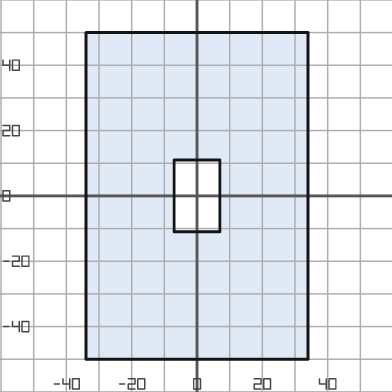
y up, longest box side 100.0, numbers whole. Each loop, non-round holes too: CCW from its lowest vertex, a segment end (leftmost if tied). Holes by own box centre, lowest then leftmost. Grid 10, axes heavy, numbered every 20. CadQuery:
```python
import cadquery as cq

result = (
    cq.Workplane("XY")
    .moveTo(-34.0, -50.0)
    .lineTo(34.0, -50.0)
    .lineTo(34.0, 50.0)
    .lineTo(-34.0, 50.0)
    .close()
    .moveTo(-7.0, -11.0)
    .lineTo(7.0, -11.0)
    .lineTo(7.0, 11.0)
    .lineTo(-7.0, 11.0)
    .close()
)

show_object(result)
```